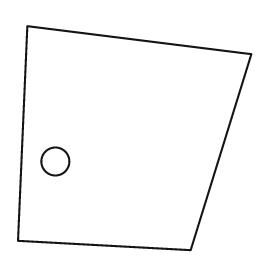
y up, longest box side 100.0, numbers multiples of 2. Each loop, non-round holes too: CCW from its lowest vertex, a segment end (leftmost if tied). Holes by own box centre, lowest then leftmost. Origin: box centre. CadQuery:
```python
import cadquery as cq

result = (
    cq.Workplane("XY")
    .moveTo(24.0, -48.0)
    .lineTo(50.0, 36.0)
    .lineTo(-46.0, 48.0)
    .lineTo(-50.0, -44.0)
    .close()
    .moveTo(-34.0, -10.0)
    .circle(6.0)
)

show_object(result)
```